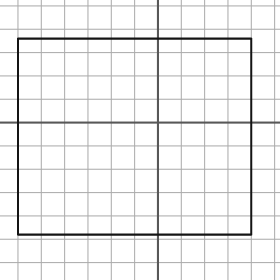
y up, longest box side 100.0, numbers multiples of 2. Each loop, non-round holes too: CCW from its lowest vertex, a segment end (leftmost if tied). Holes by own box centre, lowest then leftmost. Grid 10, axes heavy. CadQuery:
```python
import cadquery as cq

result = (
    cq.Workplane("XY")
    .moveTo(-60.0, -48.0)
    .lineTo(40.0, -48.0)
    .lineTo(40.0, 36.0)
    .lineTo(-60.0, 36.0)
    .close()
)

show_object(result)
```